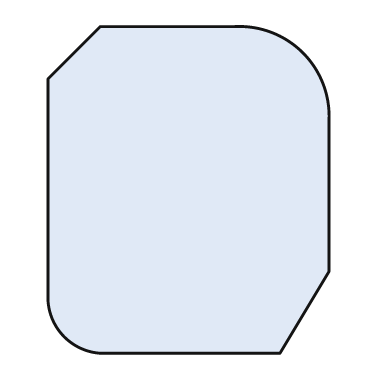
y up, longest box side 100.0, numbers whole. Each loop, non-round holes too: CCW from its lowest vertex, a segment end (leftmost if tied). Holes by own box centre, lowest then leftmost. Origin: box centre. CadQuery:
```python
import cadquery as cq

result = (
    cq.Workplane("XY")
    .moveTo(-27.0, -50.0)
    .lineTo(28.0, -50.0)
    .lineTo(43.0, -25.0)
    .lineTo(43.0, 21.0)
    .threePointArc((35.0, 42.0), (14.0, 50.0))
    .lineTo(-27.0, 50.0)
    .lineTo(-43.0, 34.0)
    .lineTo(-43.0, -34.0)
    .threePointArc((-38.0, -45.0), (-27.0, -50.0))
    .close()
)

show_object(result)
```